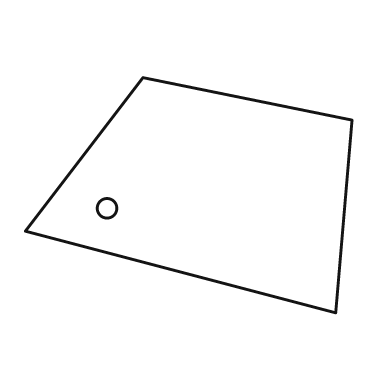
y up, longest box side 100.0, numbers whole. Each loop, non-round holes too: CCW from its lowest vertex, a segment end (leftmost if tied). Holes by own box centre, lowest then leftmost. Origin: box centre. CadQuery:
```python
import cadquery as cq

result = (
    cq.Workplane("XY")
    .moveTo(45.0, -36.0)
    .lineTo(50.0, 23.0)
    .lineTo(-14.0, 36.0)
    .lineTo(-50.0, -11.0)
    .close()
    .moveTo(-25.0, -4.0)
    .circle(3.0)
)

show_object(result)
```